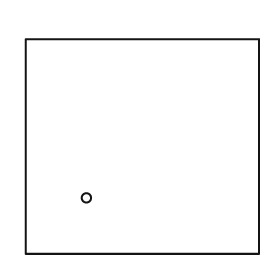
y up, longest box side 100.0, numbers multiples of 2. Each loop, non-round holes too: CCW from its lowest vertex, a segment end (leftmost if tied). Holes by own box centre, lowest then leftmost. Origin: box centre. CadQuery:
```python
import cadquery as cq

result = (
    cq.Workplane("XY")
    .moveTo(-50.0, -46.0)
    .lineTo(50.0, -46.0)
    .lineTo(50.0, 46.0)
    .lineTo(-50.0, 46.0)
    .close()
    .moveTo(-24.0, -22.0)
    .circle(2.0)
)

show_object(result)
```